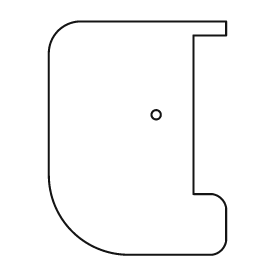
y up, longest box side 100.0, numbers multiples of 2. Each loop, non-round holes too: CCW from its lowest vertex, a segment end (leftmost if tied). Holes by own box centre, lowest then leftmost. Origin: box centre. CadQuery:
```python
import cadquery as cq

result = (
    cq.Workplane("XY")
    .moveTo(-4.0, -50.0)
    .lineTo(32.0, -50.0)
    .threePointArc((36.0, -48.0), (38.0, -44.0))
    .lineTo(38.0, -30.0)
    .threePointArc((36.0, -26.0), (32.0, -24.0))
    .lineTo(24.0, -24.0)
    .lineTo(24.0, 44.0)
    .lineTo(38.0, 44.0)
    .lineTo(38.0, 50.0)
    .lineTo(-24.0, 50.0)
    .threePointArc((-34.0, 46.0), (-38.0, 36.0))
    .lineTo(-38.0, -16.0)
    .threePointArc((-28.0, -40.0), (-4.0, -50.0))
    .close()
    .moveTo(8.0, 10.0)
    .circle(2.0)
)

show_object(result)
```